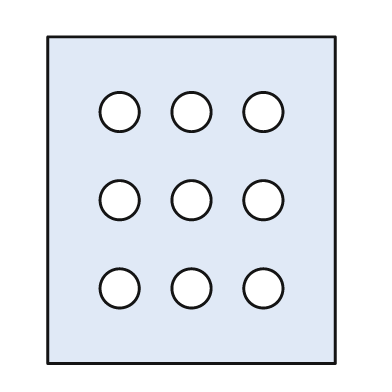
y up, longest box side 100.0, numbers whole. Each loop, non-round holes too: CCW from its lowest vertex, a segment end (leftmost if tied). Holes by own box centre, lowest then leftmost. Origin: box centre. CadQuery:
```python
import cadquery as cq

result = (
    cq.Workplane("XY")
    .moveTo(-44.0, -50.0)
    .lineTo(44.0, -50.0)
    .lineTo(44.0, 50.0)
    .lineTo(-44.0, 50.0)
    .close()
    .moveTo(-22.0, -27.0)
    .circle(6.0)
    .moveTo(0.0, -27.0)
    .circle(6.0)
    .moveTo(22.0, -27.0)
    .circle(6.0)
    .moveTo(-22.0, 0.0)
    .circle(6.0)
    .moveTo(0.0, 0.0)
    .circle(6.0)
    .moveTo(22.0, 0.0)
    .circle(6.0)
    .moveTo(-22.0, 27.0)
    .circle(6.0)
    .moveTo(0.0, 27.0)
    .circle(6.0)
    .moveTo(22.0, 27.0)
    .circle(6.0)
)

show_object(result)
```